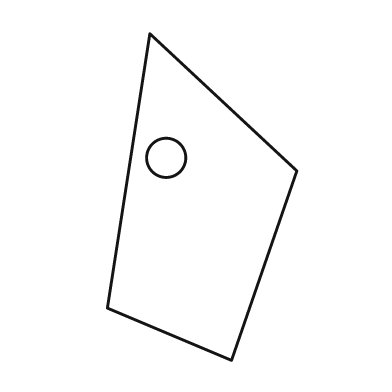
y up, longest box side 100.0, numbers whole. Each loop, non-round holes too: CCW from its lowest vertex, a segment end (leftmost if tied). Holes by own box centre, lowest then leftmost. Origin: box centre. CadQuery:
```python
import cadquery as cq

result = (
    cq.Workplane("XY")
    .moveTo(9.0, -50.0)
    .lineTo(29.0, 8.0)
    .lineTo(-16.0, 50.0)
    .lineTo(-29.0, -34.0)
    .close()
    .moveTo(-11.0, 12.0)
    .circle(6.0)
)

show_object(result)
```